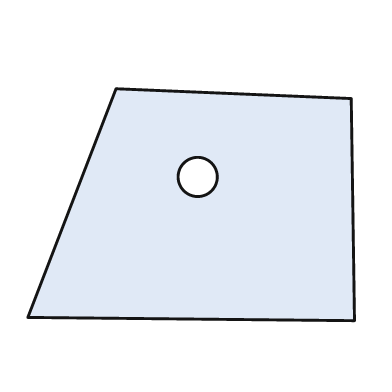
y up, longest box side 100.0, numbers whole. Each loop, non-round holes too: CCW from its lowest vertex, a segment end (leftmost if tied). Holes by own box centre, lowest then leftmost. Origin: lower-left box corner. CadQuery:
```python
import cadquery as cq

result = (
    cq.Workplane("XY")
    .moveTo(100.0, 0.0)
    .lineTo(99.0, 68.0)
    .lineTo(27.0, 71.0)
    .lineTo(0.0, 1.0)
    .close()
    .moveTo(52.0, 44.0)
    .circle(6.0)
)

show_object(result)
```